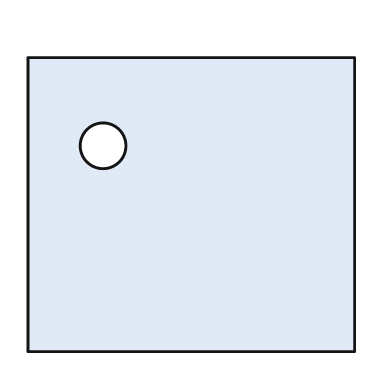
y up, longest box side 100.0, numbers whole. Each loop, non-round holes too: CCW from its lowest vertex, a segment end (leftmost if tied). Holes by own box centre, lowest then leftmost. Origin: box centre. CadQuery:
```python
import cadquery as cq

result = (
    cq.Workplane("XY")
    .moveTo(-50.0, -45.0)
    .lineTo(50.0, -45.0)
    .lineTo(50.0, 45.0)
    .lineTo(-50.0, 45.0)
    .close()
    .moveTo(-27.0, 18.0)
    .circle(7.0)
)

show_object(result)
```